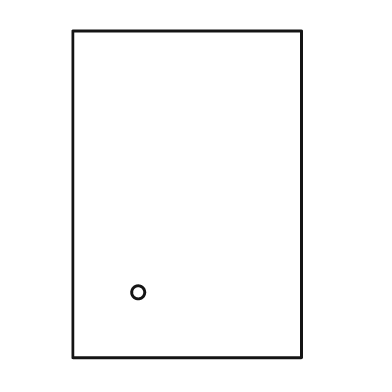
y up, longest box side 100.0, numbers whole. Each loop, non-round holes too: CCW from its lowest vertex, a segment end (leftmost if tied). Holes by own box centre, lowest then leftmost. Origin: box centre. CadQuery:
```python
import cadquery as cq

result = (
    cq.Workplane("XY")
    .moveTo(-35.0, -50.0)
    .lineTo(35.0, -50.0)
    .lineTo(35.0, 50.0)
    .lineTo(-35.0, 50.0)
    .close()
    .moveTo(-15.0, -30.0)
    .circle(2.0)
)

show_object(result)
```